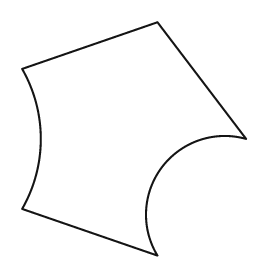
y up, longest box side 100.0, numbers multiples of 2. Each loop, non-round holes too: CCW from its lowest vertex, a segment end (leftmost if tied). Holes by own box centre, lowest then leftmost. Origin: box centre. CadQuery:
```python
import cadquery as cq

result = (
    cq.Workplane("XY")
    .moveTo(10.0, -50.0)
    .threePointArc((12.0, -12.0), (48.0, 0.0))
    .lineTo(10.0, 50.0)
    .lineTo(-48.0, 30.0)
    .threePointArc((-40.0, 0.0), (-48.0, -30.0))
    .close()
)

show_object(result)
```